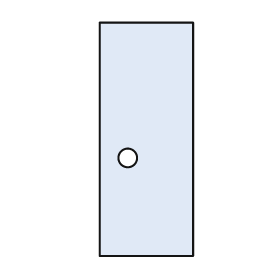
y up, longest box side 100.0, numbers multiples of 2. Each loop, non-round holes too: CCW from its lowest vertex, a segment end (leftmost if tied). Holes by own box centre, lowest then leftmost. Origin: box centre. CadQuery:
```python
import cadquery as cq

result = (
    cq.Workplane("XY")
    .moveTo(-20.0, -50.0)
    .lineTo(20.0, -50.0)
    .lineTo(20.0, 50.0)
    .lineTo(-20.0, 50.0)
    .close()
    .moveTo(-8.0, -8.0)
    .circle(4.0)
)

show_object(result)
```